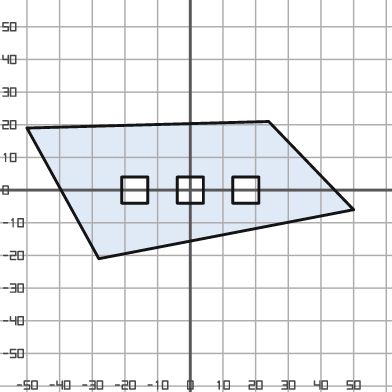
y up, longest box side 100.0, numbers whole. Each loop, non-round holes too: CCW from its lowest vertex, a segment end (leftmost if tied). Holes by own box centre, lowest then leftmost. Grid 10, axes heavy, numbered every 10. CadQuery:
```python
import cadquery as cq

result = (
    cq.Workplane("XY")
    .moveTo(-28.0, -21.0)
    .lineTo(50.0, -6.0)
    .lineTo(24.0, 21.0)
    .lineTo(-50.0, 19.0)
    .close()
    .moveTo(-21.0, -4.0)
    .lineTo(-13.0, -4.0)
    .lineTo(-13.0, 4.0)
    .lineTo(-21.0, 4.0)
    .close()
    .moveTo(-4.0, -4.0)
    .lineTo(4.0, -4.0)
    .lineTo(4.0, 4.0)
    .lineTo(-4.0, 4.0)
    .close()
    .moveTo(13.0, -4.0)
    .lineTo(21.0, -4.0)
    .lineTo(21.0, 4.0)
    .lineTo(13.0, 4.0)
    .close()
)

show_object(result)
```